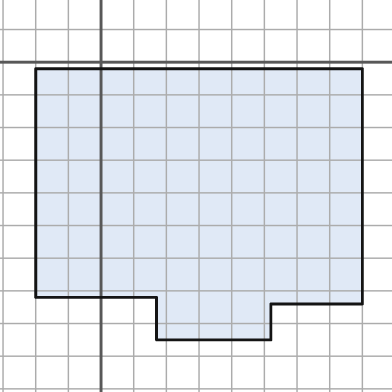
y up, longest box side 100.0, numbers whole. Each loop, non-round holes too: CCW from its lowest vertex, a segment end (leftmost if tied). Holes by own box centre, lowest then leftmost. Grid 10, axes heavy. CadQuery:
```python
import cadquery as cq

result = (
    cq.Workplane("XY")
    .moveTo(17.0, -85.0)
    .lineTo(52.0, -85.0)
    .lineTo(52.0, -74.0)
    .lineTo(80.0, -74.0)
    .lineTo(80.0, -2.0)
    .lineTo(-20.0, -2.0)
    .lineTo(-20.0, -72.0)
    .lineTo(17.0, -72.0)
    .close()
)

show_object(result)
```